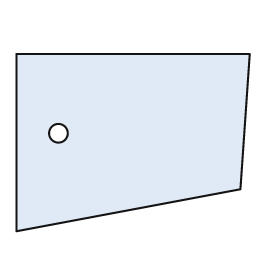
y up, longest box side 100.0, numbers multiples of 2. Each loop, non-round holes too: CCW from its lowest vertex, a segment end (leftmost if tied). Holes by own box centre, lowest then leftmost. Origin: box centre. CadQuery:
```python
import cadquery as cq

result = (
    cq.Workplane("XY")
    .moveTo(-50.0, -38.0)
    .lineTo(46.0, -20.0)
    .lineTo(50.0, 38.0)
    .lineTo(-50.0, 38.0)
    .close()
    .moveTo(-32.0, 4.0)
    .circle(4.0)
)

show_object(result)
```